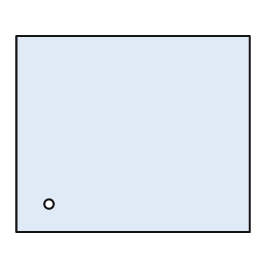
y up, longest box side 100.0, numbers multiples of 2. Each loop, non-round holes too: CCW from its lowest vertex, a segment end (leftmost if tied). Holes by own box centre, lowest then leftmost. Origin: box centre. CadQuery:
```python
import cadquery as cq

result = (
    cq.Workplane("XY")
    .moveTo(-50.0, -42.0)
    .lineTo(50.0, -42.0)
    .lineTo(50.0, 42.0)
    .lineTo(-50.0, 42.0)
    .close()
    .moveTo(-36.0, -30.0)
    .circle(2.0)
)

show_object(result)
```